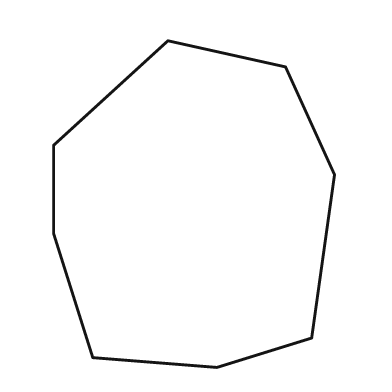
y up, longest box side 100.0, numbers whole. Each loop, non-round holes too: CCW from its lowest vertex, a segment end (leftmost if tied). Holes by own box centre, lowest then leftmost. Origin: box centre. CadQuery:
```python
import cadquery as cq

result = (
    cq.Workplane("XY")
    .moveTo(7.0, -50.0)
    .lineTo(36.0, -41.0)
    .lineTo(43.0, 9.0)
    .lineTo(28.0, 42.0)
    .lineTo(-8.0, 50.0)
    .lineTo(-43.0, 18.0)
    .lineTo(-43.0, -9.0)
    .lineTo(-31.0, -47.0)
    .close()
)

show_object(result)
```